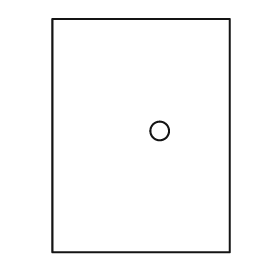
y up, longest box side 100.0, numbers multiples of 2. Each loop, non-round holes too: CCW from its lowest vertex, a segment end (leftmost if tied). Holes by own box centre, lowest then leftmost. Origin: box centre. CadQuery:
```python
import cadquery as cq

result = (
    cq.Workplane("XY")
    .moveTo(-38.0, -50.0)
    .lineTo(38.0, -50.0)
    .lineTo(38.0, 50.0)
    .lineTo(-38.0, 50.0)
    .close()
    .moveTo(8.0, 2.0)
    .circle(4.0)
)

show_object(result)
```